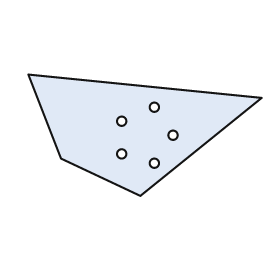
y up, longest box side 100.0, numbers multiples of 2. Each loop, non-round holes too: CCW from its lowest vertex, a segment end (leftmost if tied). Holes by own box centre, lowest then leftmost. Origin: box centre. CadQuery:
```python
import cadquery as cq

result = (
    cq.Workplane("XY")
    .moveTo(-2.0, -26.0)
    .lineTo(50.0, 16.0)
    .lineTo(-50.0, 26.0)
    .lineTo(-36.0, -10.0)
    .close()
    .moveTo(4.0, -12.0)
    .circle(2.0)
    .moveTo(-10.0, -8.0)
    .circle(2.0)
    .moveTo(12.0, 0.0)
    .circle(2.0)
    .moveTo(-10.0, 6.0)
    .circle(2.0)
    .moveTo(4.0, 12.0)
    .circle(2.0)
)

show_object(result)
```